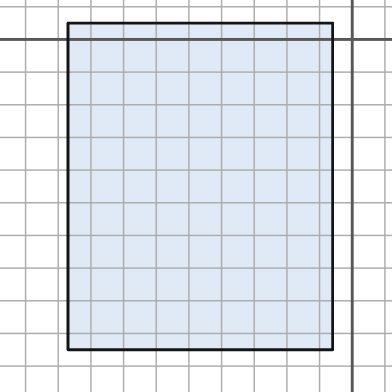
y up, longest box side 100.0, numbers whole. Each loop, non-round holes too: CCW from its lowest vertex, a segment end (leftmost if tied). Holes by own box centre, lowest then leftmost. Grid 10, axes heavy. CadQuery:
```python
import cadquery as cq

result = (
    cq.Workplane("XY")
    .moveTo(-87.0, -95.0)
    .lineTo(-6.0, -95.0)
    .lineTo(-6.0, 5.0)
    .lineTo(-87.0, 5.0)
    .close()
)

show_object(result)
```